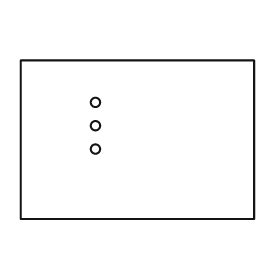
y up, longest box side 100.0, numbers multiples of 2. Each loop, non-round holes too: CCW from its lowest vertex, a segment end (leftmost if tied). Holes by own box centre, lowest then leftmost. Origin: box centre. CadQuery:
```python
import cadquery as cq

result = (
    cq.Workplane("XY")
    .moveTo(-50.0, -34.0)
    .lineTo(50.0, -34.0)
    .lineTo(50.0, 34.0)
    .lineTo(-50.0, 34.0)
    .close()
    .moveTo(-18.0, -4.0)
    .circle(2.0)
    .moveTo(-18.0, 6.0)
    .circle(2.0)
    .moveTo(-18.0, 16.0)
    .circle(2.0)
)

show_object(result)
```